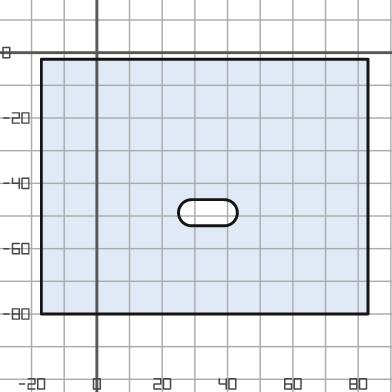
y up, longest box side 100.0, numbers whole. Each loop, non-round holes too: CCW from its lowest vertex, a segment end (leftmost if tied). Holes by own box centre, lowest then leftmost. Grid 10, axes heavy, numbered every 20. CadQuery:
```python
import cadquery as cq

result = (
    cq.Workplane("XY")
    .moveTo(-17.0, -80.0)
    .lineTo(83.0, -80.0)
    .lineTo(83.0, -2.0)
    .lineTo(-17.0, -2.0)
    .close()
    .moveTo(29.0, -53.0)
    .lineTo(39.0, -53.0)
    .threePointArc((43.0, -49.0), (39.0, -45.0))
    .lineTo(29.0, -45.0)
    .threePointArc((25.0, -49.0), (29.0, -53.0))
    .close()
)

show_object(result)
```